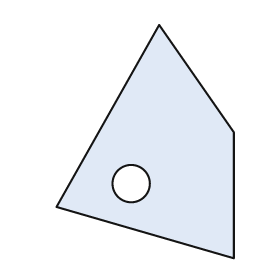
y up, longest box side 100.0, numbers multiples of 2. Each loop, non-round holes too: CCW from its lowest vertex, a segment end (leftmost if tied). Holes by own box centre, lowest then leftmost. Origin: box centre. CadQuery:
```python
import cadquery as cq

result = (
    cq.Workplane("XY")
    .moveTo(38.0, -50.0)
    .lineTo(38.0, 4.0)
    .lineTo(6.0, 50.0)
    .lineTo(-38.0, -28.0)
    .close()
    .moveTo(-6.0, -18.0)
    .circle(8.0)
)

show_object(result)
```